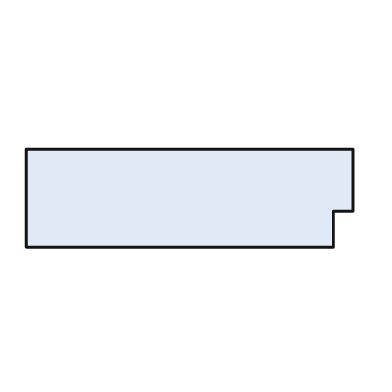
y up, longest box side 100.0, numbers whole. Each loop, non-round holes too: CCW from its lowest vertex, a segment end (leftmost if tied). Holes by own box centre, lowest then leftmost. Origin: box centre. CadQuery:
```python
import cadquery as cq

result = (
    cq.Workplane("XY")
    .moveTo(-50.0, -15.0)
    .lineTo(44.0, -15.0)
    .lineTo(44.0, -4.0)
    .lineTo(50.0, -4.0)
    .lineTo(50.0, 15.0)
    .lineTo(-50.0, 15.0)
    .close()
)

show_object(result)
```